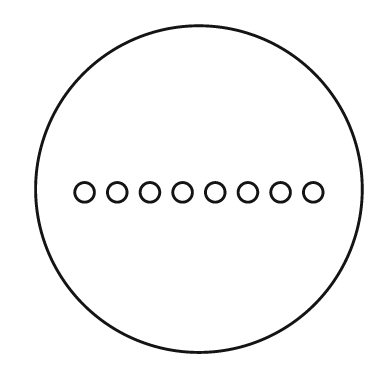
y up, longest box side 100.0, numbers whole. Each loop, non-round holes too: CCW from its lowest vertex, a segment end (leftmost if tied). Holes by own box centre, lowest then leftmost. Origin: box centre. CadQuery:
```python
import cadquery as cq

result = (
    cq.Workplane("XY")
    .moveTo(0.0, 0.0)
    .circle(50.0)
    .moveTo(-35.0, -1.0)
    .circle(3.0)
    .moveTo(-25.0, -1.0)
    .circle(3.0)
    .moveTo(-15.0, -1.0)
    .circle(3.0)
    .moveTo(-5.0, -1.0)
    .circle(3.0)
    .moveTo(5.0, -1.0)
    .circle(3.0)
    .moveTo(15.0, -1.0)
    .circle(3.0)
    .moveTo(25.0, -1.0)
    .circle(3.0)
    .moveTo(35.0, -1.0)
    .circle(3.0)
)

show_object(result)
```